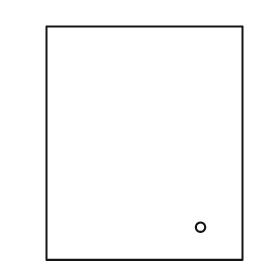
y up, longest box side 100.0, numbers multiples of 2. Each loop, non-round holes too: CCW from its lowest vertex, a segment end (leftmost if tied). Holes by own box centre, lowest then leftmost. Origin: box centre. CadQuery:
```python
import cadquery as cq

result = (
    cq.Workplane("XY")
    .moveTo(-42.0, -50.0)
    .lineTo(42.0, -50.0)
    .lineTo(42.0, 50.0)
    .lineTo(-42.0, 50.0)
    .close()
    .moveTo(24.0, -36.0)
    .circle(2.0)
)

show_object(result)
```